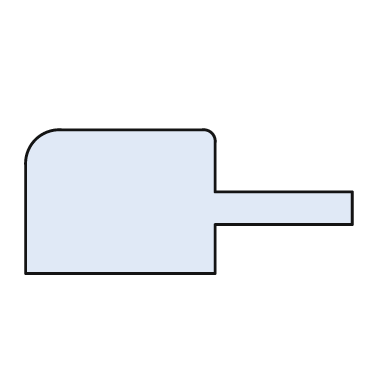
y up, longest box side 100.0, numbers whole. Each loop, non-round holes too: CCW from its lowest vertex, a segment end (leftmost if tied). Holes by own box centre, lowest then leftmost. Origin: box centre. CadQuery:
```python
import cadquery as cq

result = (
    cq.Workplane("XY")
    .moveTo(-50.0, -22.0)
    .lineTo(8.0, -22.0)
    .lineTo(8.0, -7.0)
    .lineTo(50.0, -7.0)
    .lineTo(50.0, 3.0)
    .lineTo(8.0, 3.0)
    .lineTo(8.0, 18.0)
    .threePointArc((7.0, 21.0), (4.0, 22.0))
    .lineTo(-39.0, 22.0)
    .threePointArc((-47.0, 19.0), (-50.0, 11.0))
    .close()
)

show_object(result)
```